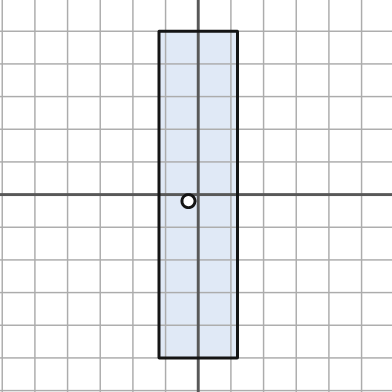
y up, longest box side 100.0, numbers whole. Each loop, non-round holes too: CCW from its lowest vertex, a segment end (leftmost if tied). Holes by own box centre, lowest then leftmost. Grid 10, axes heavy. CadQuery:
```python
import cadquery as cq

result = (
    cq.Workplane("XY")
    .moveTo(-12.0, -50.0)
    .lineTo(12.0, -50.0)
    .lineTo(12.0, 50.0)
    .lineTo(-12.0, 50.0)
    .close()
    .moveTo(-3.0, -2.0)
    .circle(2.0)
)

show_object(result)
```